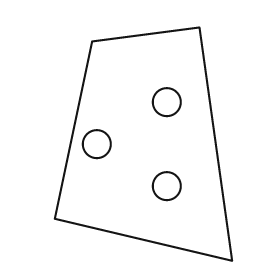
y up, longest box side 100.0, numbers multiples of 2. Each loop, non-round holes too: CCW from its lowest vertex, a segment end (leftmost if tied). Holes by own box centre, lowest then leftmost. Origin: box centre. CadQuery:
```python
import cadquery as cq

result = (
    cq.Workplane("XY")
    .moveTo(38.0, -50.0)
    .lineTo(24.0, 50.0)
    .lineTo(-22.0, 44.0)
    .lineTo(-38.0, -32.0)
    .close()
    .moveTo(10.0, -18.0)
    .circle(6.0)
    .moveTo(-20.0, 0.0)
    .circle(6.0)
    .moveTo(10.0, 18.0)
    .circle(6.0)
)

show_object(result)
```